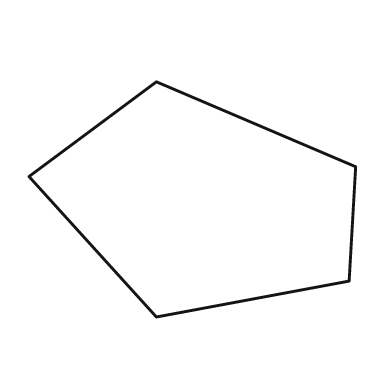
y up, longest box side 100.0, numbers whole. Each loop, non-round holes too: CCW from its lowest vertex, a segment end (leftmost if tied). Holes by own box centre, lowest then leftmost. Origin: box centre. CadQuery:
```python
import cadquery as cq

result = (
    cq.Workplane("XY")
    .moveTo(-11.0, -36.0)
    .lineTo(48.0, -25.0)
    .lineTo(50.0, 10.0)
    .lineTo(-11.0, 36.0)
    .lineTo(-50.0, 7.0)
    .close()
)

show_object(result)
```